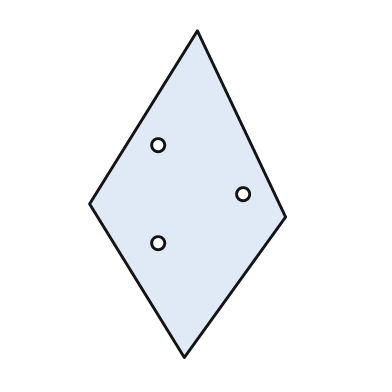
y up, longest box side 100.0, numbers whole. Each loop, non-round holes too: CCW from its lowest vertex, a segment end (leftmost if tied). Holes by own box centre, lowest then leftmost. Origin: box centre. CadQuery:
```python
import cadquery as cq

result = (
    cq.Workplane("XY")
    .moveTo(-1.0, -50.0)
    .lineTo(30.0, -7.0)
    .lineTo(3.0, 50.0)
    .lineTo(-30.0, -3.0)
    .close()
    .moveTo(-9.0, -15.0)
    .circle(2.0)
    .moveTo(17.0, 0.0)
    .circle(2.0)
    .moveTo(-9.0, 15.0)
    .circle(2.0)
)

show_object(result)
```